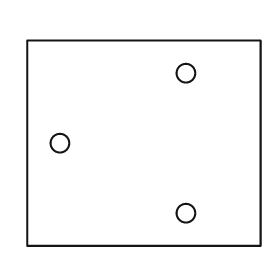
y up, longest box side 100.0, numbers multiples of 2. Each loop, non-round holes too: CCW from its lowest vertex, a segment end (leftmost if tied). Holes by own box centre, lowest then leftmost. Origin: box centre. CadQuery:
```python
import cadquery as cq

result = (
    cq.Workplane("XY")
    .moveTo(-50.0, -44.0)
    .lineTo(50.0, -44.0)
    .lineTo(50.0, 44.0)
    .lineTo(-50.0, 44.0)
    .close()
    .moveTo(18.0, -30.0)
    .circle(4.0)
    .moveTo(-36.0, 0.0)
    .circle(4.0)
    .moveTo(18.0, 30.0)
    .circle(4.0)
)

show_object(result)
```